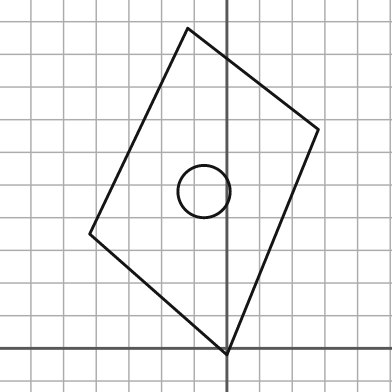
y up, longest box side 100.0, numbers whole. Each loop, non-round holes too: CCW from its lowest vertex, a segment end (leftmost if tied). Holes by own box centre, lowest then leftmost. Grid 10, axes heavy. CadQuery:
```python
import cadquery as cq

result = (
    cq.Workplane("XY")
    .moveTo(0.0, -2.0)
    .lineTo(28.0, 67.0)
    .lineTo(-12.0, 98.0)
    .lineTo(-42.0, 35.0)
    .close()
    .moveTo(-7.0, 48.0)
    .circle(8.0)
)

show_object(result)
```